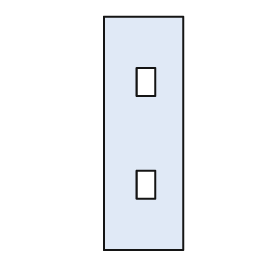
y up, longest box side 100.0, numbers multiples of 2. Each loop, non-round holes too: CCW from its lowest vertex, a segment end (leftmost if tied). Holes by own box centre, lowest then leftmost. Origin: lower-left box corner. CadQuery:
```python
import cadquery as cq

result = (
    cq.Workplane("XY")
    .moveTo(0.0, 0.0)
    .lineTo(34.0, 0.0)
    .lineTo(34.0, 100.0)
    .lineTo(0.0, 100.0)
    .close()
    .moveTo(14.0, 22.0)
    .lineTo(22.0, 22.0)
    .lineTo(22.0, 34.0)
    .lineTo(14.0, 34.0)
    .close()
    .moveTo(14.0, 66.0)
    .lineTo(22.0, 66.0)
    .lineTo(22.0, 78.0)
    .lineTo(14.0, 78.0)
    .close()
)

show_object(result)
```